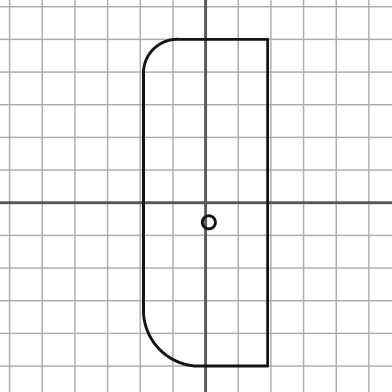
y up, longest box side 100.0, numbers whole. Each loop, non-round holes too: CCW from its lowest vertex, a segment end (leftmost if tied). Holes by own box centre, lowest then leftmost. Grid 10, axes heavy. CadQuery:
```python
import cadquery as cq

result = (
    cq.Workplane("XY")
    .moveTo(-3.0, -50.0)
    .lineTo(19.0, -50.0)
    .lineTo(19.0, 50.0)
    .lineTo(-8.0, 50.0)
    .threePointArc((-16.0, 47.0), (-19.0, 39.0))
    .lineTo(-19.0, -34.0)
    .threePointArc((-14.0, -45.0), (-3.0, -50.0))
    .close()
    .moveTo(1.0, -6.0)
    .circle(2.0)
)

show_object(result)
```